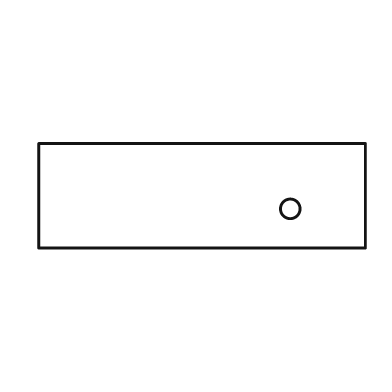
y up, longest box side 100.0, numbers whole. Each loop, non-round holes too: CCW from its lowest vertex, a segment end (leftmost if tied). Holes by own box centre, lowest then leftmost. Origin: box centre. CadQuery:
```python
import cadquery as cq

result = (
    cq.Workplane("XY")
    .moveTo(-50.0, -16.0)
    .lineTo(50.0, -16.0)
    .lineTo(50.0, 16.0)
    .lineTo(-50.0, 16.0)
    .close()
    .moveTo(27.0, -4.0)
    .circle(3.0)
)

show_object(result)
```